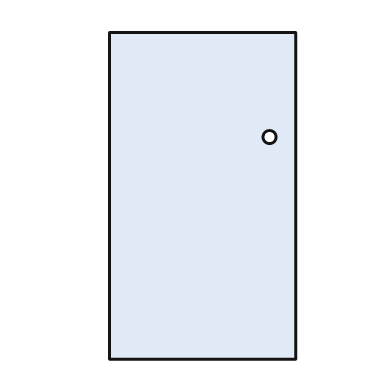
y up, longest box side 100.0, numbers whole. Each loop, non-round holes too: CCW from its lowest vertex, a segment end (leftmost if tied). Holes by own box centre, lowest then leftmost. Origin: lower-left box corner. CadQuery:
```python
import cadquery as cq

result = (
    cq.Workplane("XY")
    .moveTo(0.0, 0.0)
    .lineTo(57.0, 0.0)
    .lineTo(57.0, 100.0)
    .lineTo(0.0, 100.0)
    .close()
    .moveTo(49.0, 68.0)
    .circle(2.0)
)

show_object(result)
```